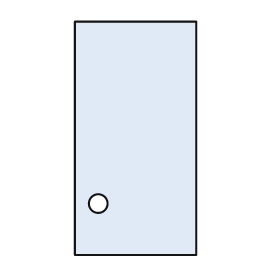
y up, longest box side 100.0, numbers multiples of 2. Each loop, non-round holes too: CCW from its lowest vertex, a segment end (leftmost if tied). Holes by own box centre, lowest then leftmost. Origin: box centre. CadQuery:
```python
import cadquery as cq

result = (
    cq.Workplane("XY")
    .moveTo(-26.0, -50.0)
    .lineTo(26.0, -50.0)
    .lineTo(26.0, 50.0)
    .lineTo(-26.0, 50.0)
    .close()
    .moveTo(-16.0, -28.0)
    .circle(4.0)
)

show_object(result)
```